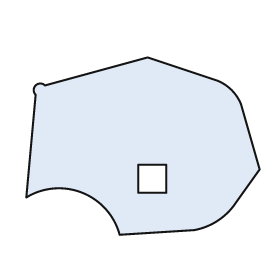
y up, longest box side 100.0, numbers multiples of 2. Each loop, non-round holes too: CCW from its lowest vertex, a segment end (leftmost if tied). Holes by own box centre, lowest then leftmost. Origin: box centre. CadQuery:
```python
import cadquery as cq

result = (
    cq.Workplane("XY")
    .moveTo(-10.0, -38.0)
    .lineTo(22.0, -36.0)
    .threePointArc((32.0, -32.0), (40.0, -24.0))
    .lineTo(50.0, -10.0)
    .lineTo(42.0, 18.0)
    .threePointArc((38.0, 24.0), (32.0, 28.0))
    .lineTo(2.0, 38.0)
    .lineTo(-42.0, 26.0)
    .threePointArc((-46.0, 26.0), (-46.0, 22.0))
    .lineTo(-50.0, -22.0)
    .threePointArc((-26.0, -20.0), (-10.0, -38.0))
    .close()
    .moveTo(-2.0, -20.0)
    .lineTo(10.0, -20.0)
    .lineTo(10.0, -8.0)
    .lineTo(-2.0, -8.0)
    .close()
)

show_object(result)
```